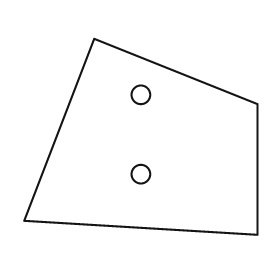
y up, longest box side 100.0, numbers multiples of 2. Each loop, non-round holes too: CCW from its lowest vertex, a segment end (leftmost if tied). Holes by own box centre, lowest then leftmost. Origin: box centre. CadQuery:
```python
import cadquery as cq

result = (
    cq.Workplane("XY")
    .moveTo(50.0, -42.0)
    .lineTo(50.0, 14.0)
    .lineTo(-20.0, 42.0)
    .lineTo(-50.0, -36.0)
    .close()
    .moveTo(0.0, -16.0)
    .circle(4.0)
    .moveTo(0.0, 18.0)
    .circle(4.0)
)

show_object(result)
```